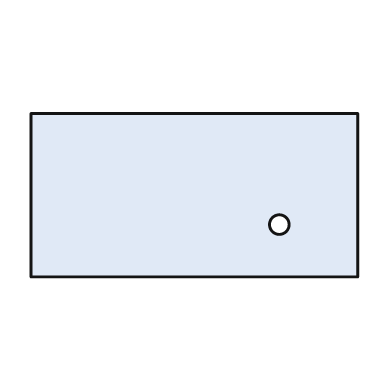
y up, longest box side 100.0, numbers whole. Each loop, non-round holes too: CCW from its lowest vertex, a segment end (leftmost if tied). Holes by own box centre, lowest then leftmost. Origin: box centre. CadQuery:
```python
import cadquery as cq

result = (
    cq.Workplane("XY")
    .moveTo(-50.0, -25.0)
    .lineTo(50.0, -25.0)
    .lineTo(50.0, 25.0)
    .lineTo(-50.0, 25.0)
    .close()
    .moveTo(26.0, -9.0)
    .circle(3.0)
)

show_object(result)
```